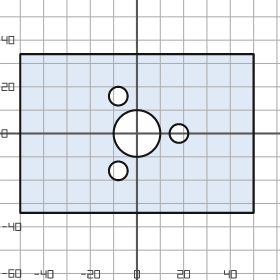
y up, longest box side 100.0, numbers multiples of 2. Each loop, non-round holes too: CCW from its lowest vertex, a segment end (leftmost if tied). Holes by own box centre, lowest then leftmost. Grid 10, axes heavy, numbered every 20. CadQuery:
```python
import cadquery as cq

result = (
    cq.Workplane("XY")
    .moveTo(-50.0, -34.0)
    .lineTo(50.0, -34.0)
    .lineTo(50.0, 34.0)
    .lineTo(-50.0, 34.0)
    .close()
    .moveTo(-8.0, -16.0)
    .circle(4.0)
    .moveTo(0.0, 0.0)
    .circle(10.0)
    .moveTo(18.0, 0.0)
    .circle(4.0)
    .moveTo(-8.0, 16.0)
    .circle(4.0)
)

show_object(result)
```